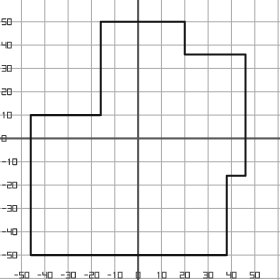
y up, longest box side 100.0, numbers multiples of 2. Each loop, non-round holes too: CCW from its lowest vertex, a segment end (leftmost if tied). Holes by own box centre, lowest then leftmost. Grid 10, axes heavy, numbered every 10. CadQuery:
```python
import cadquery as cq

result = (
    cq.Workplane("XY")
    .moveTo(-46.0, -50.0)
    .lineTo(38.0, -50.0)
    .lineTo(38.0, -16.0)
    .lineTo(46.0, -16.0)
    .lineTo(46.0, 36.0)
    .lineTo(20.0, 36.0)
    .lineTo(20.0, 50.0)
    .lineTo(-16.0, 50.0)
    .lineTo(-16.0, 10.0)
    .lineTo(-46.0, 10.0)
    .close()
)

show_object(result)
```